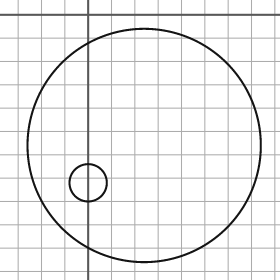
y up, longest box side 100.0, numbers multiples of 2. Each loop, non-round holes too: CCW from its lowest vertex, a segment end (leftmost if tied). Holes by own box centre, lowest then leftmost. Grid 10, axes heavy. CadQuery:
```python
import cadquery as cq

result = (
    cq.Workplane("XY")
    .moveTo(24.0, -56.0)
    .circle(50.0)
    .moveTo(0.0, -72.0)
    .circle(8.0)
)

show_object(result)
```